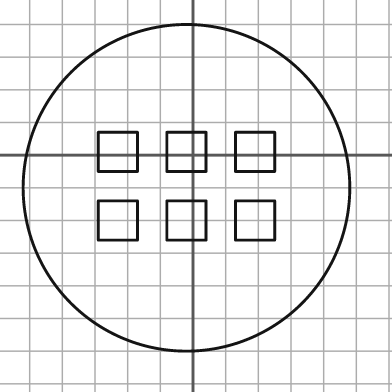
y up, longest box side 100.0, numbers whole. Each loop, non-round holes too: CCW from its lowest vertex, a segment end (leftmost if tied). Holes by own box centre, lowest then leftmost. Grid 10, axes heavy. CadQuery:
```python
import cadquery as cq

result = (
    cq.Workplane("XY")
    .moveTo(-2.0, -10.0)
    .circle(50.0)
    .moveTo(-29.0, -26.0)
    .lineTo(-17.0, -26.0)
    .lineTo(-17.0, -14.0)
    .lineTo(-29.0, -14.0)
    .close()
    .moveTo(-8.0, -26.0)
    .lineTo(4.0, -26.0)
    .lineTo(4.0, -14.0)
    .lineTo(-8.0, -14.0)
    .close()
    .moveTo(13.0, -26.0)
    .lineTo(25.0, -26.0)
    .lineTo(25.0, -14.0)
    .lineTo(13.0, -14.0)
    .close()
    .moveTo(-29.0, -5.0)
    .lineTo(-17.0, -5.0)
    .lineTo(-17.0, 7.0)
    .lineTo(-29.0, 7.0)
    .close()
    .moveTo(-8.0, -5.0)
    .lineTo(4.0, -5.0)
    .lineTo(4.0, 7.0)
    .lineTo(-8.0, 7.0)
    .close()
    .moveTo(13.0, -5.0)
    .lineTo(25.0, -5.0)
    .lineTo(25.0, 7.0)
    .lineTo(13.0, 7.0)
    .close()
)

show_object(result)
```